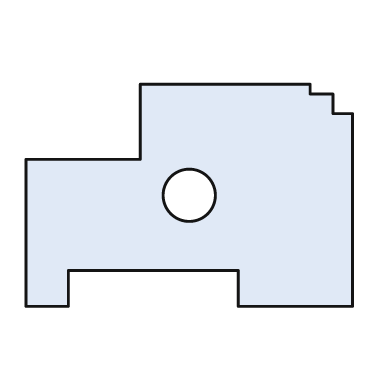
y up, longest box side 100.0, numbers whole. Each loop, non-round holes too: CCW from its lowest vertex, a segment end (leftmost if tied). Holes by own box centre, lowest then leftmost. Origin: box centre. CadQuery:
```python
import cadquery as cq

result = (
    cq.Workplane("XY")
    .moveTo(-50.0, -34.0)
    .lineTo(-37.0, -34.0)
    .lineTo(-37.0, -23.0)
    .lineTo(15.0, -23.0)
    .lineTo(15.0, -34.0)
    .lineTo(50.0, -34.0)
    .lineTo(50.0, 25.0)
    .lineTo(44.0, 25.0)
    .lineTo(44.0, 31.0)
    .lineTo(37.0, 31.0)
    .lineTo(37.0, 34.0)
    .lineTo(-15.0, 34.0)
    .lineTo(-15.0, 11.0)
    .lineTo(-50.0, 11.0)
    .close()
    .moveTo(0.0, 0.0)
    .circle(8.0)
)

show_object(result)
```